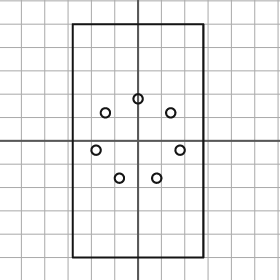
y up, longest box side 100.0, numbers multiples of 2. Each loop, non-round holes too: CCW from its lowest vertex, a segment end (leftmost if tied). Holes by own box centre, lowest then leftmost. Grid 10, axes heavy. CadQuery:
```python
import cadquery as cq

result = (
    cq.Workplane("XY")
    .moveTo(-28.0, -50.0)
    .lineTo(28.0, -50.0)
    .lineTo(28.0, 50.0)
    .lineTo(-28.0, 50.0)
    .close()
    .moveTo(-8.0, -16.0)
    .circle(2.0)
    .moveTo(8.0, -16.0)
    .circle(2.0)
    .moveTo(-18.0, -4.0)
    .circle(2.0)
    .moveTo(18.0, -4.0)
    .circle(2.0)
    .moveTo(-14.0, 12.0)
    .circle(2.0)
    .moveTo(14.0, 12.0)
    .circle(2.0)
    .moveTo(0.0, 18.0)
    .circle(2.0)
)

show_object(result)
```